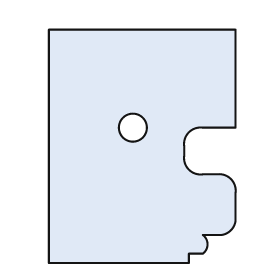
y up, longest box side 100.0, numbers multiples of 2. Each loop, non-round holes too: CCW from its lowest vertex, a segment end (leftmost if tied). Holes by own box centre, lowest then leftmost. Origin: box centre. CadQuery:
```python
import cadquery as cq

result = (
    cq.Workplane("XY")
    .moveTo(-40.0, -50.0)
    .lineTo(20.0, -50.0)
    .lineTo(20.0, -46.0)
    .lineTo(26.0, -46.0)
    .threePointArc((28.0, -42.0), (26.0, -38.0))
    .lineTo(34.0, -38.0)
    .threePointArc((38.0, -36.0), (40.0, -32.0))
    .lineTo(40.0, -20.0)
    .threePointArc((38.0, -14.0), (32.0, -12.0))
    .lineTo(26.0, -12.0)
    .threePointArc((20.0, -10.0), (18.0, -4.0))
    .lineTo(18.0, 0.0)
    .threePointArc((20.0, 6.0), (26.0, 8.0))
    .lineTo(40.0, 8.0)
    .lineTo(40.0, 50.0)
    .lineTo(-40.0, 50.0)
    .close()
    .moveTo(-4.0, 8.0)
    .circle(6.0)
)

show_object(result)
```